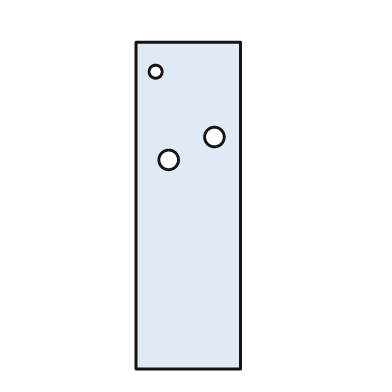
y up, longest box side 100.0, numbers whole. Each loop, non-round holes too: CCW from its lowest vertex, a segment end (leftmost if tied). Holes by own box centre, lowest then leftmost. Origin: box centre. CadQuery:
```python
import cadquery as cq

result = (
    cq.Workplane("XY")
    .moveTo(-16.0, -50.0)
    .lineTo(16.0, -50.0)
    .lineTo(16.0, 50.0)
    .lineTo(-16.0, 50.0)
    .close()
    .moveTo(-6.0, 14.0)
    .circle(3.0)
    .moveTo(8.0, 21.0)
    .circle(3.0)
    .moveTo(-10.0, 41.0)
    .circle(2.0)
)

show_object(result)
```